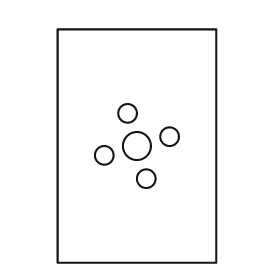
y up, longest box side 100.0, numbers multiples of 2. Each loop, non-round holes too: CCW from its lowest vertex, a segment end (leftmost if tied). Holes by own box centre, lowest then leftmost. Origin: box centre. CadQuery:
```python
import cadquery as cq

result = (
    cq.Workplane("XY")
    .moveTo(-34.0, -50.0)
    .lineTo(34.0, -50.0)
    .lineTo(34.0, 50.0)
    .lineTo(-34.0, 50.0)
    .close()
    .moveTo(4.0, -14.0)
    .circle(4.0)
    .moveTo(-14.0, -4.0)
    .circle(4.0)
    .moveTo(0.0, 0.0)
    .circle(6.0)
    .moveTo(14.0, 4.0)
    .circle(4.0)
    .moveTo(-4.0, 14.0)
    .circle(4.0)
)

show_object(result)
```